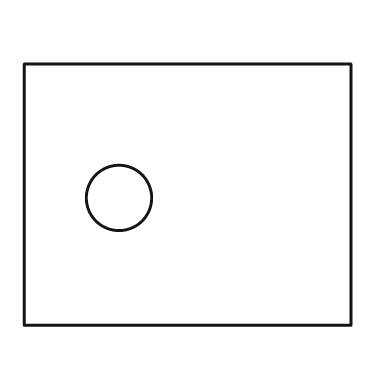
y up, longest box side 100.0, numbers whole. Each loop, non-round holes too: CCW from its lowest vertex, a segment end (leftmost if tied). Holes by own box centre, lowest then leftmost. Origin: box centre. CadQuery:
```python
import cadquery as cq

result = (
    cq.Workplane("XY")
    .moveTo(-50.0, -40.0)
    .lineTo(50.0, -40.0)
    .lineTo(50.0, 40.0)
    .lineTo(-50.0, 40.0)
    .close()
    .moveTo(-21.0, -1.0)
    .circle(10.0)
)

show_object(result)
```